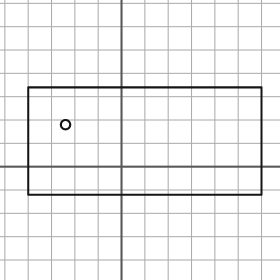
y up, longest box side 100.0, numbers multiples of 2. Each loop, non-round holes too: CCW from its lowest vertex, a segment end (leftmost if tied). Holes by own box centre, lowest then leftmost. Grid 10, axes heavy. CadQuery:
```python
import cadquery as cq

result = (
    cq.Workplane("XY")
    .moveTo(-40.0, -12.0)
    .lineTo(60.0, -12.0)
    .lineTo(60.0, 34.0)
    .lineTo(-40.0, 34.0)
    .close()
    .moveTo(-24.0, 18.0)
    .circle(2.0)
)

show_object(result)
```